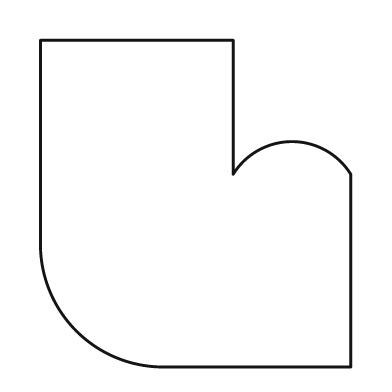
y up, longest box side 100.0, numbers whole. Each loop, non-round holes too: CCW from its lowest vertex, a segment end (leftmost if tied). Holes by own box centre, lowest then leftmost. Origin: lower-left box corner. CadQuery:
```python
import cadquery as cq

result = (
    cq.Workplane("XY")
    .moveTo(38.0, 0.0)
    .lineTo(95.0, 0.0)
    .lineTo(95.0, 59.0)
    .threePointArc((77.0, 69.0), (59.0, 59.0))
    .lineTo(59.0, 100.0)
    .lineTo(0.0, 100.0)
    .lineTo(0.0, 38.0)
    .threePointArc((11.0, 11.0), (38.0, 0.0))
    .close()
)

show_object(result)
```